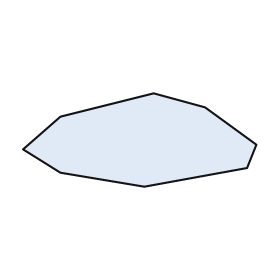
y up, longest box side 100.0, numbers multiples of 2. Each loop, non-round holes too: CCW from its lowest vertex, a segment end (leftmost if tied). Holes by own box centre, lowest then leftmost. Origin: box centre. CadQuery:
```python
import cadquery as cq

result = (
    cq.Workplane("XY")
    .moveTo(2.0, -20.0)
    .lineTo(46.0, -12.0)
    .lineTo(50.0, -2.0)
    .lineTo(28.0, 14.0)
    .lineTo(6.0, 20.0)
    .lineTo(-34.0, 10.0)
    .lineTo(-50.0, -4.0)
    .lineTo(-34.0, -14.0)
    .close()
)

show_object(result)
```